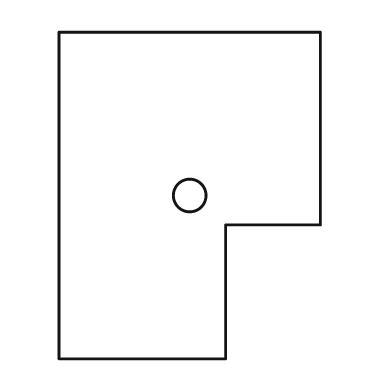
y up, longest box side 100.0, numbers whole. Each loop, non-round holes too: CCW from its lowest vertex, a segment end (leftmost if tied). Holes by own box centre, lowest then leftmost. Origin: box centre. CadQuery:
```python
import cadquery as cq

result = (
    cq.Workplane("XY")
    .moveTo(-40.0, -50.0)
    .lineTo(11.0, -50.0)
    .lineTo(11.0, -9.0)
    .lineTo(40.0, -9.0)
    .lineTo(40.0, 50.0)
    .lineTo(-40.0, 50.0)
    .close()
    .moveTo(0.0, 0.0)
    .circle(5.0)
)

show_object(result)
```